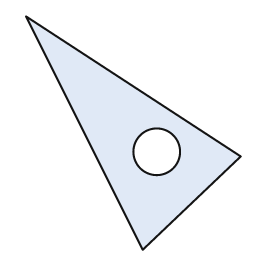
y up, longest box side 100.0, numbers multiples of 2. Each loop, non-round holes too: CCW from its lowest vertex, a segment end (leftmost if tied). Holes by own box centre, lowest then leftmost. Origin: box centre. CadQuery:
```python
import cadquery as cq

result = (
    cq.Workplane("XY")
    .moveTo(4.0, -50.0)
    .lineTo(46.0, -10.0)
    .lineTo(-46.0, 50.0)
    .close()
    .moveTo(10.0, -8.0)
    .circle(10.0)
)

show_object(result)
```